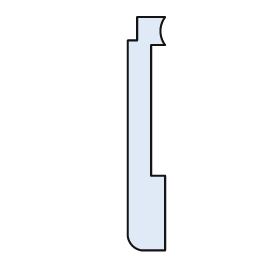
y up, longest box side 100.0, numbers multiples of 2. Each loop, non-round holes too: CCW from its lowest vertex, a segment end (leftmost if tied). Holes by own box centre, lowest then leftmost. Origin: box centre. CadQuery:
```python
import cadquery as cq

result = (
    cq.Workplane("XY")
    .moveTo(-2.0, -50.0)
    .lineTo(8.0, -50.0)
    .lineTo(8.0, -18.0)
    .lineTo(2.0, -18.0)
    .lineTo(2.0, 38.0)
    .lineTo(8.0, 38.0)
    .threePointArc((6.0, 44.0), (8.0, 50.0))
    .lineTo(-4.0, 50.0)
    .lineTo(-4.0, 40.0)
    .lineTo(-8.0, 40.0)
    .lineTo(-8.0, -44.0)
    .threePointArc((-6.0, -48.0), (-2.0, -50.0))
    .close()
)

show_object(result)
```